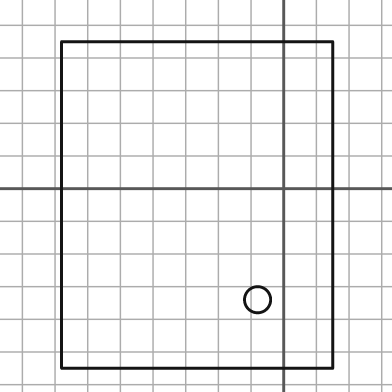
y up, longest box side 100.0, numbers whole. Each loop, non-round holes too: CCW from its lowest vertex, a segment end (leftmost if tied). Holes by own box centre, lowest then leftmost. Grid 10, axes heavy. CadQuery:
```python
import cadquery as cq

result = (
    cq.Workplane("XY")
    .moveTo(-68.0, -55.0)
    .lineTo(15.0, -55.0)
    .lineTo(15.0, 45.0)
    .lineTo(-68.0, 45.0)
    .close()
    .moveTo(-8.0, -34.0)
    .circle(4.0)
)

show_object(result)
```